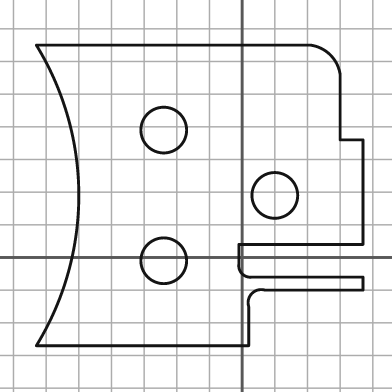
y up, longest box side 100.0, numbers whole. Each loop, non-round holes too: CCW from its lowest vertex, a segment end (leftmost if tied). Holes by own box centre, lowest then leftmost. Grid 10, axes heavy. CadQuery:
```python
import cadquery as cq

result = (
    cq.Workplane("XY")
    .moveTo(-63.0, -27.0)
    .lineTo(2.0, -27.0)
    .lineTo(2.0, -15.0)
    .threePointArc((3.0, -11.0), (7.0, -10.0))
    .lineTo(37.0, -10.0)
    .lineTo(37.0, -6.0)
    .lineTo(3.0, -6.0)
    .threePointArc((0.0, -5.0), (-1.0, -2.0))
    .lineTo(-1.0, 4.0)
    .lineTo(37.0, 4.0)
    .lineTo(37.0, 36.0)
    .lineTo(30.0, 36.0)
    .lineTo(30.0, 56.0)
    .threePointArc((27.0, 62.0), (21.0, 65.0))
    .lineTo(-63.0, 65.0)
    .threePointArc((-50.0, 19.0), (-63.0, -27.0))
    .close()
    .moveTo(-24.0, -1.0)
    .circle(7.0)
    .moveTo(10.0, 19.0)
    .circle(7.0)
    .moveTo(-24.0, 39.0)
    .circle(7.0)
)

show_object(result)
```